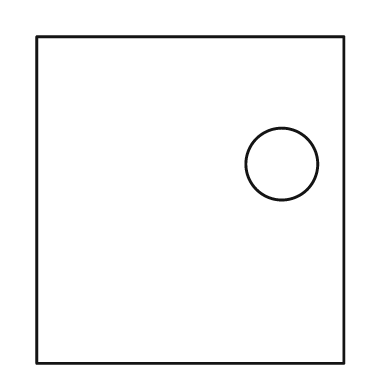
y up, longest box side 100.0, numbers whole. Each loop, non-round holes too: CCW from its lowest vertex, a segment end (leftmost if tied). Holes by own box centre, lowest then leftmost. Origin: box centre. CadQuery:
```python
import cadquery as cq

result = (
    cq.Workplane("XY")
    .moveTo(-47.0, -50.0)
    .lineTo(47.0, -50.0)
    .lineTo(47.0, 50.0)
    .lineTo(-47.0, 50.0)
    .close()
    .moveTo(28.0, 11.0)
    .circle(11.0)
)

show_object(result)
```